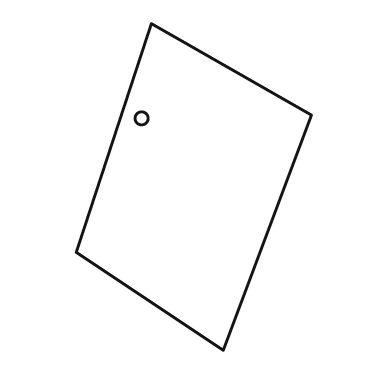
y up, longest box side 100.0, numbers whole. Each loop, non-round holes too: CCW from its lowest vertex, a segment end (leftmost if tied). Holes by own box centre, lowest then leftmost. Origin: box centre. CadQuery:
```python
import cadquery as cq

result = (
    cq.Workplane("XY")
    .moveTo(9.0, -50.0)
    .lineTo(36.0, 22.0)
    .lineTo(-13.0, 50.0)
    .lineTo(-36.0, -20.0)
    .close()
    .moveTo(-16.0, 21.0)
    .circle(2.0)
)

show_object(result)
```